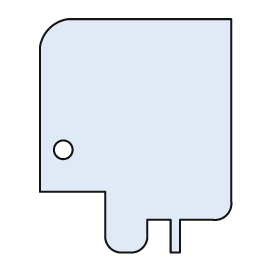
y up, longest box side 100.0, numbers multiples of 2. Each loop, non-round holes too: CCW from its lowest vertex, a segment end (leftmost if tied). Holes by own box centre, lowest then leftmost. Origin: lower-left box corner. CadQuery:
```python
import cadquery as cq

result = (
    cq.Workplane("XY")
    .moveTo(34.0, 0.0)
    .lineTo(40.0, 0.0)
    .threePointArc((44.0, 2.0), (46.0, 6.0))
    .lineTo(46.0, 14.0)
    .lineTo(56.0, 14.0)
    .lineTo(56.0, 0.0)
    .lineTo(60.0, 0.0)
    .lineTo(60.0, 14.0)
    .lineTo(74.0, 14.0)
    .threePointArc((80.0, 16.0), (82.0, 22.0))
    .lineTo(82.0, 100.0)
    .lineTo(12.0, 100.0)
    .threePointArc((4.0, 96.0), (0.0, 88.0))
    .lineTo(0.0, 26.0)
    .lineTo(28.0, 26.0)
    .lineTo(28.0, 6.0)
    .threePointArc((30.0, 2.0), (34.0, 0.0))
    .close()
    .moveTo(10.0, 44.0)
    .circle(4.0)
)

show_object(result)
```